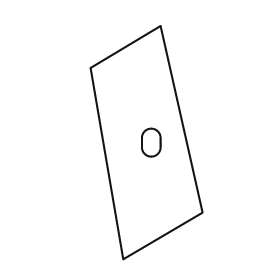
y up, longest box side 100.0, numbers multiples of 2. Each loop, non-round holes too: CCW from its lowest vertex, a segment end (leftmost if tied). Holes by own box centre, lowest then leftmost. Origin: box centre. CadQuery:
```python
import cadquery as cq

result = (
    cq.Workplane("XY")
    .moveTo(-10.0, -50.0)
    .lineTo(24.0, -30.0)
    .lineTo(6.0, 50.0)
    .lineTo(-24.0, 32.0)
    .close()
    .moveTo(-2.0, -2.0)
    .threePointArc((2.0, -6.0), (6.0, -2.0))
    .lineTo(6.0, 2.0)
    .threePointArc((2.0, 6.0), (-2.0, 2.0))
    .close()
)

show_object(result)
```